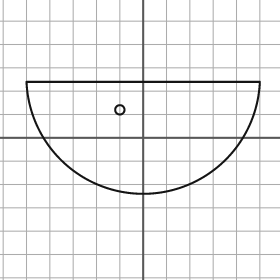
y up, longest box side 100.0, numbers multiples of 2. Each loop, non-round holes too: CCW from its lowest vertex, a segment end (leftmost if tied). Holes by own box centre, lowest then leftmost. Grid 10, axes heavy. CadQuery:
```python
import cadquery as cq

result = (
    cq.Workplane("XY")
    .moveTo(-50.0, 24.0)
    .threePointArc((0.0, -24.0), (50.0, 24.0))
    .close()
    .moveTo(-10.0, 12.0)
    .circle(2.0)
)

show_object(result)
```